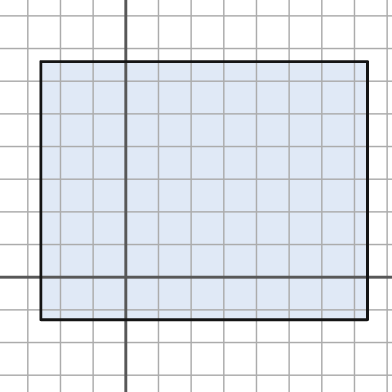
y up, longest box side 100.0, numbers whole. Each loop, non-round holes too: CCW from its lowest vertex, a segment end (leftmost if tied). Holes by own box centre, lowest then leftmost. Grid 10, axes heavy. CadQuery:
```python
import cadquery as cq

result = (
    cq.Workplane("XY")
    .moveTo(-26.0, -13.0)
    .lineTo(74.0, -13.0)
    .lineTo(74.0, 66.0)
    .lineTo(-26.0, 66.0)
    .close()
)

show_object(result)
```